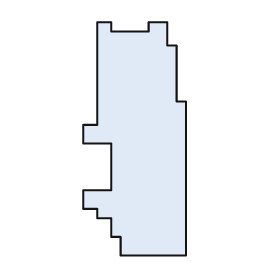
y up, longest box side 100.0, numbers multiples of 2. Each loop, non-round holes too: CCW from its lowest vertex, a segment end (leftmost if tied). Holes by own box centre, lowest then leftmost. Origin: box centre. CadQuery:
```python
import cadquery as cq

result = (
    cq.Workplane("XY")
    .moveTo(-6.0, -50.0)
    .lineTo(22.0, -50.0)
    .lineTo(22.0, 16.0)
    .lineTo(18.0, 16.0)
    .lineTo(18.0, 40.0)
    .lineTo(14.0, 40.0)
    .lineTo(14.0, 50.0)
    .lineTo(6.0, 50.0)
    .lineTo(6.0, 46.0)
    .lineTo(-10.0, 46.0)
    .lineTo(-10.0, 50.0)
    .lineTo(-16.0, 50.0)
    .lineTo(-16.0, 6.0)
    .lineTo(-22.0, 6.0)
    .lineTo(-22.0, -2.0)
    .lineTo(-10.0, -2.0)
    .lineTo(-10.0, -22.0)
    .lineTo(-22.0, -22.0)
    .lineTo(-22.0, -30.0)
    .lineTo(-16.0, -30.0)
    .lineTo(-16.0, -34.0)
    .lineTo(-10.0, -34.0)
    .lineTo(-10.0, -42.0)
    .lineTo(-6.0, -42.0)
    .close()
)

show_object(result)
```